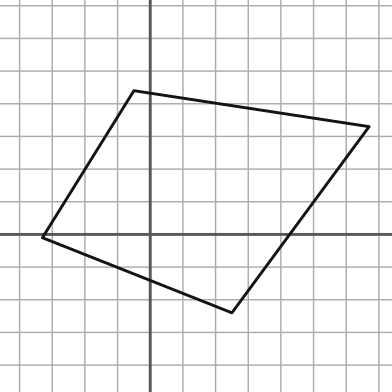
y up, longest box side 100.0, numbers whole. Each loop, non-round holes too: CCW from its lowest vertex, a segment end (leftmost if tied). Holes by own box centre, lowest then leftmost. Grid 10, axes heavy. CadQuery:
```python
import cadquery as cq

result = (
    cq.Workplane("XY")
    .moveTo(25.0, -24.0)
    .lineTo(67.0, 33.0)
    .lineTo(-5.0, 44.0)
    .lineTo(-33.0, -1.0)
    .close()
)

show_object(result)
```